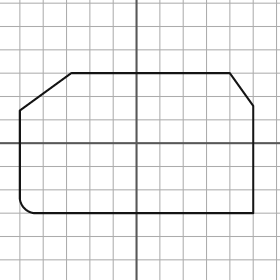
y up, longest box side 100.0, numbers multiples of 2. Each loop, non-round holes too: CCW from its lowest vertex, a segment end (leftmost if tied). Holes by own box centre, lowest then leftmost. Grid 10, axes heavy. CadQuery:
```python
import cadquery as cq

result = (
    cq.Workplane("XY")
    .moveTo(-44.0, -30.0)
    .lineTo(50.0, -30.0)
    .lineTo(50.0, 16.0)
    .lineTo(40.0, 30.0)
    .lineTo(-28.0, 30.0)
    .lineTo(-50.0, 14.0)
    .lineTo(-50.0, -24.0)
    .threePointArc((-48.0, -28.0), (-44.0, -30.0))
    .close()
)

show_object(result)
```